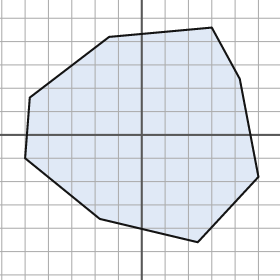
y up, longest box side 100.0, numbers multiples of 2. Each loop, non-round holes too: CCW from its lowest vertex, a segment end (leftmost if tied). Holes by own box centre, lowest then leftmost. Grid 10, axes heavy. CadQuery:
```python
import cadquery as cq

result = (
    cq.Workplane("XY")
    .moveTo(24.0, -46.0)
    .lineTo(50.0, -18.0)
    .lineTo(42.0, 24.0)
    .lineTo(30.0, 46.0)
    .lineTo(-14.0, 42.0)
    .lineTo(-48.0, 16.0)
    .lineTo(-50.0, -10.0)
    .lineTo(-18.0, -36.0)
    .close()
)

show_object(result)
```